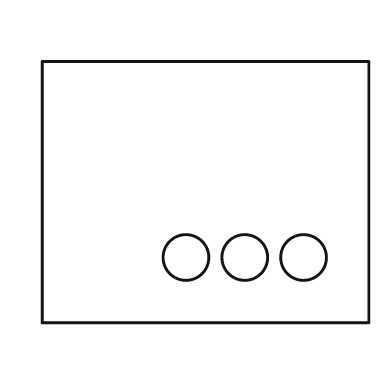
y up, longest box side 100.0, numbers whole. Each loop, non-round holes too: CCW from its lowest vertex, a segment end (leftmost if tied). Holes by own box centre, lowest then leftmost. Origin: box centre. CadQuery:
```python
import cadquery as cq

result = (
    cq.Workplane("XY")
    .moveTo(-50.0, -40.0)
    .lineTo(50.0, -40.0)
    .lineTo(50.0, 40.0)
    .lineTo(-50.0, 40.0)
    .close()
    .moveTo(-6.0, -20.0)
    .circle(7.0)
    .moveTo(12.0, -20.0)
    .circle(7.0)
    .moveTo(30.0, -20.0)
    .circle(7.0)
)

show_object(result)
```